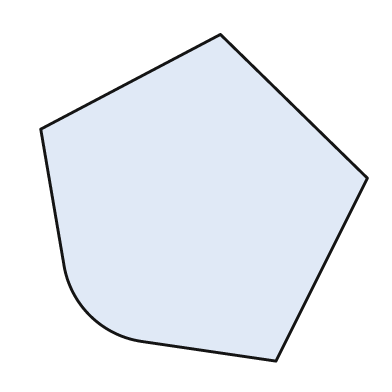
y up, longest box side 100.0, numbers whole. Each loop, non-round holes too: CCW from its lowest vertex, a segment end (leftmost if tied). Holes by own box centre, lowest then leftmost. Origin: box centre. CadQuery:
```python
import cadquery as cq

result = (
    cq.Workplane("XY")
    .moveTo(22.0, -50.0)
    .lineTo(50.0, 6.0)
    .lineTo(5.0, 50.0)
    .lineTo(-50.0, 21.0)
    .lineTo(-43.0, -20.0)
    .threePointArc((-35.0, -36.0), (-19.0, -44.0))
    .close()
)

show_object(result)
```